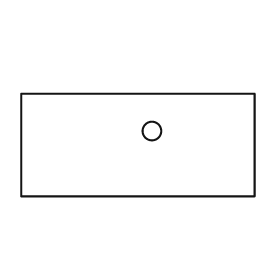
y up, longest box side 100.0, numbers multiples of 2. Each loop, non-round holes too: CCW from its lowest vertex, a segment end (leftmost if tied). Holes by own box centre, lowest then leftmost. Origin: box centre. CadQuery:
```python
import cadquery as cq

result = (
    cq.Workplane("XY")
    .moveTo(-50.0, -22.0)
    .lineTo(50.0, -22.0)
    .lineTo(50.0, 22.0)
    .lineTo(-50.0, 22.0)
    .close()
    .moveTo(6.0, 6.0)
    .circle(4.0)
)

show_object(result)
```